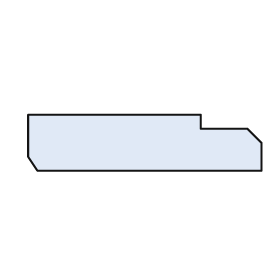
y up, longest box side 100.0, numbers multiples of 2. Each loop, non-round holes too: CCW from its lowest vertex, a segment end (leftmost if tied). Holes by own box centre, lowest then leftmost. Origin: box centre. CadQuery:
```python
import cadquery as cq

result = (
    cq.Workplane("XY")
    .moveTo(-46.0, -12.0)
    .lineTo(50.0, -12.0)
    .lineTo(50.0, 0.0)
    .lineTo(44.0, 6.0)
    .lineTo(24.0, 6.0)
    .lineTo(24.0, 12.0)
    .lineTo(-50.0, 12.0)
    .lineTo(-50.0, -6.0)
    .close()
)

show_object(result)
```